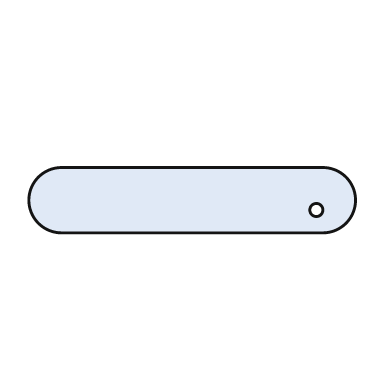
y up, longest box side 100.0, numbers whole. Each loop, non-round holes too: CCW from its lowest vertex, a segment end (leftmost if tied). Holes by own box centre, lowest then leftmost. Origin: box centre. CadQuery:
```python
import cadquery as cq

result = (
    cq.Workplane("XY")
    .moveTo(-40.0, -10.0)
    .lineTo(40.0, -10.0)
    .threePointArc((50.0, 0.0), (40.0, 10.0))
    .lineTo(-40.0, 10.0)
    .threePointArc((-50.0, 0.0), (-40.0, -10.0))
    .close()
    .moveTo(38.0, -3.0)
    .circle(2.0)
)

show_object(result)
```